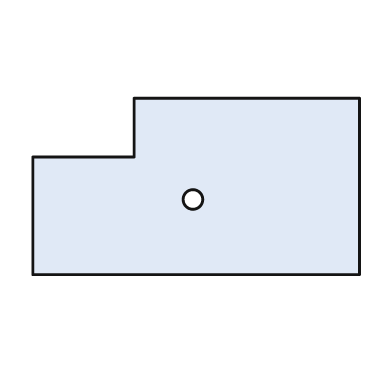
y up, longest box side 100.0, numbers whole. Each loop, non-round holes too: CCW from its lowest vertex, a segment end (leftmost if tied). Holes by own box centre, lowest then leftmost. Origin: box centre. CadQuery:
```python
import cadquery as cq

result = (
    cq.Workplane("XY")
    .moveTo(-50.0, -27.0)
    .lineTo(50.0, -27.0)
    .lineTo(50.0, 27.0)
    .lineTo(-19.0, 27.0)
    .lineTo(-19.0, 9.0)
    .lineTo(-50.0, 9.0)
    .close()
    .moveTo(-1.0, -4.0)
    .circle(3.0)
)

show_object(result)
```